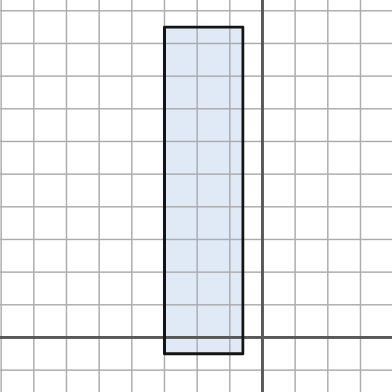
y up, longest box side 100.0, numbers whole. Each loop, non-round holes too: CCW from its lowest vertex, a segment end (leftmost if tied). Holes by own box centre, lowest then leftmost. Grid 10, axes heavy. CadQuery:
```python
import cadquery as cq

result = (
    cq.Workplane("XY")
    .moveTo(-30.0, -5.0)
    .lineTo(-6.0, -5.0)
    .lineTo(-6.0, 95.0)
    .lineTo(-30.0, 95.0)
    .close()
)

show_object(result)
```